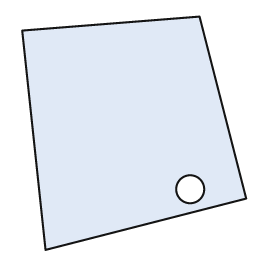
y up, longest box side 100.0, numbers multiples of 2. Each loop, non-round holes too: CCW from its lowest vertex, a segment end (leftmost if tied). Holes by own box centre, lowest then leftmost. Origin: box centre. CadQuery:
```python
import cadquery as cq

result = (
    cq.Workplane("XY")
    .moveTo(-38.0, -50.0)
    .lineTo(48.0, -28.0)
    .lineTo(28.0, 50.0)
    .lineTo(-48.0, 44.0)
    .close()
    .moveTo(24.0, -24.0)
    .circle(6.0)
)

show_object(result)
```